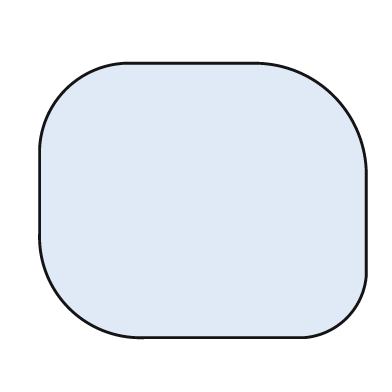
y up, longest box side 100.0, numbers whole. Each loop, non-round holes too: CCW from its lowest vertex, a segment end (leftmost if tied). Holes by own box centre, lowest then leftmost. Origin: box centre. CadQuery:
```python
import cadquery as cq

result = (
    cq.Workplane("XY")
    .moveTo(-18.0, -42.0)
    .lineTo(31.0, -42.0)
    .threePointArc((44.0, -36.0), (50.0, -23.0))
    .lineTo(50.0, 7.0)
    .threePointArc((40.0, 32.0), (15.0, 42.0))
    .lineTo(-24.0, 42.0)
    .threePointArc((-42.0, 34.0), (-50.0, 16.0))
    .lineTo(-50.0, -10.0)
    .threePointArc((-41.0, -33.0), (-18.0, -42.0))
    .close()
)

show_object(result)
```